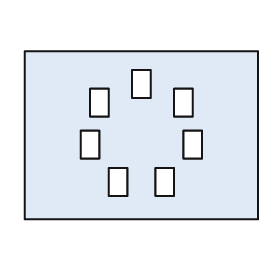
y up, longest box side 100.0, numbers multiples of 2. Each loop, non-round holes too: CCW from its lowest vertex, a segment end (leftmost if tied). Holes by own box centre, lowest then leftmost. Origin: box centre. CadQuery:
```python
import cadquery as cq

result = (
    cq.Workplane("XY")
    .moveTo(-50.0, -36.0)
    .lineTo(50.0, -36.0)
    .lineTo(50.0, 36.0)
    .lineTo(-50.0, 36.0)
    .close()
    .moveTo(-14.0, -26.0)
    .lineTo(-6.0, -26.0)
    .lineTo(-6.0, -14.0)
    .lineTo(-14.0, -14.0)
    .close()
    .moveTo(6.0, -26.0)
    .lineTo(14.0, -26.0)
    .lineTo(14.0, -14.0)
    .lineTo(6.0, -14.0)
    .close()
    .moveTo(-26.0, -10.0)
    .lineTo(-18.0, -10.0)
    .lineTo(-18.0, 2.0)
    .lineTo(-26.0, 2.0)
    .close()
    .moveTo(18.0, -10.0)
    .lineTo(26.0, -10.0)
    .lineTo(26.0, 2.0)
    .lineTo(18.0, 2.0)
    .close()
    .moveTo(-22.0, 8.0)
    .lineTo(-14.0, 8.0)
    .lineTo(-14.0, 20.0)
    .lineTo(-22.0, 20.0)
    .close()
    .moveTo(14.0, 8.0)
    .lineTo(22.0, 8.0)
    .lineTo(22.0, 20.0)
    .lineTo(14.0, 20.0)
    .close()
    .moveTo(-4.0, 16.0)
    .lineTo(4.0, 16.0)
    .lineTo(4.0, 28.0)
    .lineTo(-4.0, 28.0)
    .close()
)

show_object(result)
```